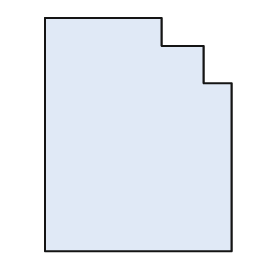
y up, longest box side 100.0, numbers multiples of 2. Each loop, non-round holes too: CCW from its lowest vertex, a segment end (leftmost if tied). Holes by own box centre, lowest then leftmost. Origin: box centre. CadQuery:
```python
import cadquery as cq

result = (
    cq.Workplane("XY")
    .moveTo(-40.0, -50.0)
    .lineTo(40.0, -50.0)
    .lineTo(40.0, 22.0)
    .lineTo(28.0, 22.0)
    .lineTo(28.0, 38.0)
    .lineTo(10.0, 38.0)
    .lineTo(10.0, 50.0)
    .lineTo(-40.0, 50.0)
    .close()
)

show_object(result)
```